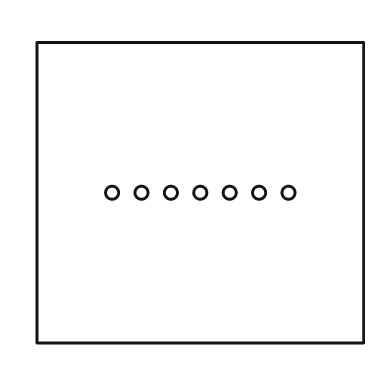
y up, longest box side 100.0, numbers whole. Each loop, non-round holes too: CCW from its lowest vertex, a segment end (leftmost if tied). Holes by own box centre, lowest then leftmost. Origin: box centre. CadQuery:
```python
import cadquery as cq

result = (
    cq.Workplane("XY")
    .moveTo(-50.0, -46.0)
    .lineTo(50.0, -46.0)
    .lineTo(50.0, 46.0)
    .lineTo(-50.0, 46.0)
    .close()
    .moveTo(-27.0, 0.0)
    .circle(2.0)
    .moveTo(-18.0, 0.0)
    .circle(2.0)
    .moveTo(-9.0, 0.0)
    .circle(2.0)
    .moveTo(0.0, 0.0)
    .circle(2.0)
    .moveTo(9.0, 0.0)
    .circle(2.0)
    .moveTo(18.0, 0.0)
    .circle(2.0)
    .moveTo(27.0, 0.0)
    .circle(2.0)
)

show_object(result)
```